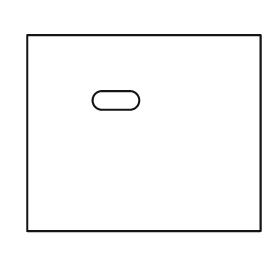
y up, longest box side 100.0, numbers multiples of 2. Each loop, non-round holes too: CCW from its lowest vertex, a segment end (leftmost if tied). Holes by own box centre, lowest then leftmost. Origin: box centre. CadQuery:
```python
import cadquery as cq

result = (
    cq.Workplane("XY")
    .moveTo(-50.0, -42.0)
    .lineTo(50.0, -42.0)
    .lineTo(50.0, 42.0)
    .lineTo(-50.0, 42.0)
    .close()
    .moveTo(-18.0, 10.0)
    .lineTo(-6.0, 10.0)
    .threePointArc((-2.0, 14.0), (-6.0, 18.0))
    .lineTo(-18.0, 18.0)
    .threePointArc((-22.0, 14.0), (-18.0, 10.0))
    .close()
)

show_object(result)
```